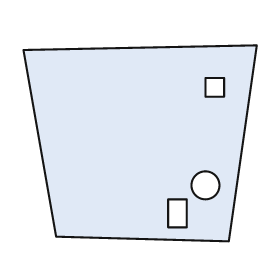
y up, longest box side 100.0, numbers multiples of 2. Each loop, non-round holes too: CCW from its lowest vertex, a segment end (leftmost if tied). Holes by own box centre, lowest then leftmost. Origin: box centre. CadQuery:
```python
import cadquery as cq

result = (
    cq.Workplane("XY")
    .moveTo(38.0, -42.0)
    .lineTo(50.0, 42.0)
    .lineTo(-50.0, 40.0)
    .lineTo(-36.0, -40.0)
    .close()
    .moveTo(12.0, -36.0)
    .lineTo(20.0, -36.0)
    .lineTo(20.0, -24.0)
    .lineTo(12.0, -24.0)
    .close()
    .moveTo(28.0, -18.0)
    .circle(6.0)
    .moveTo(28.0, 20.0)
    .lineTo(36.0, 20.0)
    .lineTo(36.0, 28.0)
    .lineTo(28.0, 28.0)
    .close()
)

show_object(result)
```